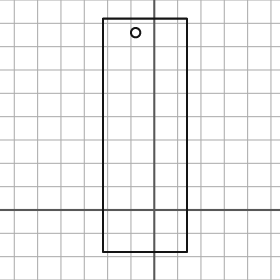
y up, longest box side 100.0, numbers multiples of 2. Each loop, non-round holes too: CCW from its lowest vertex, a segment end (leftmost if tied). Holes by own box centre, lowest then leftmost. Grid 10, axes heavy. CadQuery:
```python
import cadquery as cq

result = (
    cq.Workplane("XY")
    .moveTo(-22.0, -18.0)
    .lineTo(14.0, -18.0)
    .lineTo(14.0, 82.0)
    .lineTo(-22.0, 82.0)
    .close()
    .moveTo(-8.0, 76.0)
    .circle(2.0)
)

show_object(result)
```